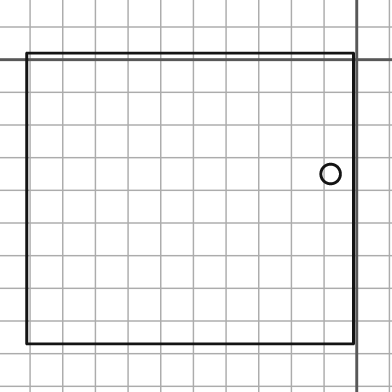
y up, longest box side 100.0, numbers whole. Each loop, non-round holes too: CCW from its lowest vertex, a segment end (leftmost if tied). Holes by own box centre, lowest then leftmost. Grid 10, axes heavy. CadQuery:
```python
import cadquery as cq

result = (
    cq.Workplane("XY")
    .moveTo(-101.0, -87.0)
    .lineTo(-1.0, -87.0)
    .lineTo(-1.0, 2.0)
    .lineTo(-101.0, 2.0)
    .close()
    .moveTo(-8.0, -35.0)
    .circle(3.0)
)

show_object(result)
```